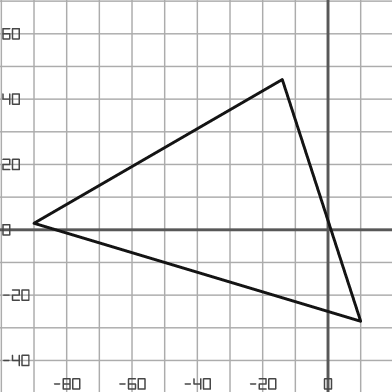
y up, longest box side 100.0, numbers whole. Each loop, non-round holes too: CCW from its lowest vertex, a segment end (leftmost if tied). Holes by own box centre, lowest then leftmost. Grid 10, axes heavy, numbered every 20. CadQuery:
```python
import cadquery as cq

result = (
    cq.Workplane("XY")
    .moveTo(10.0, -28.0)
    .lineTo(-14.0, 46.0)
    .lineTo(-90.0, 2.0)
    .close()
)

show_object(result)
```